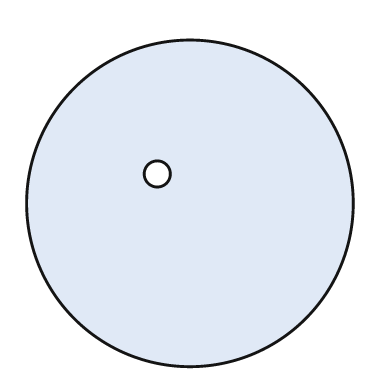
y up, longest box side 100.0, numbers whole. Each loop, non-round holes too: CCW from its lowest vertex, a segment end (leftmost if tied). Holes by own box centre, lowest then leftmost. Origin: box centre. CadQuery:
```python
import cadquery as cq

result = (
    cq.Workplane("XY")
    .moveTo(0.0, 0.0)
    .circle(50.0)
    .moveTo(-10.0, 9.0)
    .circle(4.0)
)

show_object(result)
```